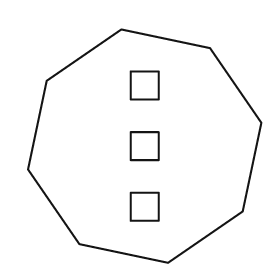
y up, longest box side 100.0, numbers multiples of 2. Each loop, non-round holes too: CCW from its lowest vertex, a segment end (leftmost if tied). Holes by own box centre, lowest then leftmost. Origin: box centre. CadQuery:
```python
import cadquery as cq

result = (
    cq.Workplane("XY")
    .moveTo(10.0, -50.0)
    .lineTo(42.0, -28.0)
    .lineTo(50.0, 10.0)
    .lineTo(28.0, 42.0)
    .lineTo(-10.0, 50.0)
    .lineTo(-42.0, 28.0)
    .lineTo(-50.0, -10.0)
    .lineTo(-28.0, -42.0)
    .close()
    .moveTo(-6.0, -32.0)
    .lineTo(6.0, -32.0)
    .lineTo(6.0, -20.0)
    .lineTo(-6.0, -20.0)
    .close()
    .moveTo(-6.0, -6.0)
    .lineTo(6.0, -6.0)
    .lineTo(6.0, 6.0)
    .lineTo(-6.0, 6.0)
    .close()
    .moveTo(-6.0, 20.0)
    .lineTo(6.0, 20.0)
    .lineTo(6.0, 32.0)
    .lineTo(-6.0, 32.0)
    .close()
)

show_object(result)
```